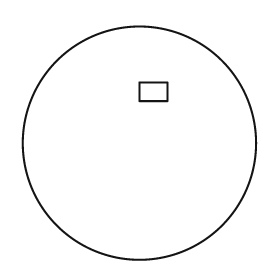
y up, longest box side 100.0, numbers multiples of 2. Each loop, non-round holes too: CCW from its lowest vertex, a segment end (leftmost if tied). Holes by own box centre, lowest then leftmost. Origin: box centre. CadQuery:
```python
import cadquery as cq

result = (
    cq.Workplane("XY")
    .moveTo(0.0, 0.0)
    .circle(50.0)
    .moveTo(0.0, 18.0)
    .lineTo(12.0, 18.0)
    .lineTo(12.0, 26.0)
    .lineTo(0.0, 26.0)
    .close()
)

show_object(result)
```